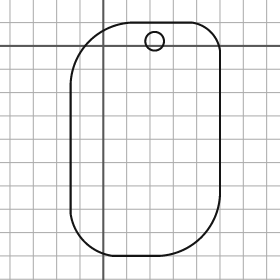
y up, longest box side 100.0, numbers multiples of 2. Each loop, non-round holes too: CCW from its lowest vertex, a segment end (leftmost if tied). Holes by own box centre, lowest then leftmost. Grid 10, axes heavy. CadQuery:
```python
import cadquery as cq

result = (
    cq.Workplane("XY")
    .moveTo(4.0, -90.0)
    .lineTo(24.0, -90.0)
    .threePointArc((42.0, -82.0), (50.0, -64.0))
    .lineTo(50.0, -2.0)
    .threePointArc((46.0, 6.0), (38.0, 10.0))
    .lineTo(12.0, 10.0)
    .threePointArc((-6.0, 2.0), (-14.0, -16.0))
    .lineTo(-14.0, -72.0)
    .threePointArc((-8.0, -84.0), (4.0, -90.0))
    .close()
    .moveTo(22.0, 2.0)
    .circle(4.0)
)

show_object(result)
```